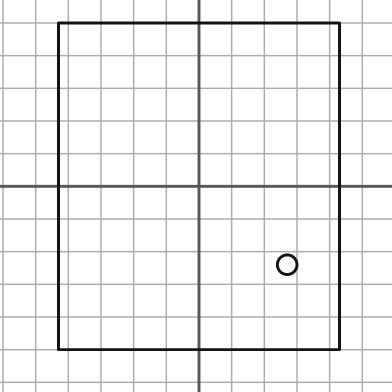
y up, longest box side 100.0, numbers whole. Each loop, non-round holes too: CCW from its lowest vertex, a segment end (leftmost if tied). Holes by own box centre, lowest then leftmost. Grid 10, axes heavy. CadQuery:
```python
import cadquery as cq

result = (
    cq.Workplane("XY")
    .moveTo(-43.0, -50.0)
    .lineTo(43.0, -50.0)
    .lineTo(43.0, 50.0)
    .lineTo(-43.0, 50.0)
    .close()
    .moveTo(27.0, -24.0)
    .circle(3.0)
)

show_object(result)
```